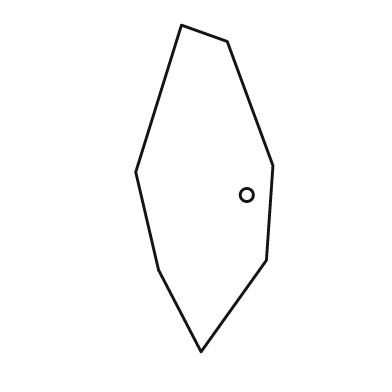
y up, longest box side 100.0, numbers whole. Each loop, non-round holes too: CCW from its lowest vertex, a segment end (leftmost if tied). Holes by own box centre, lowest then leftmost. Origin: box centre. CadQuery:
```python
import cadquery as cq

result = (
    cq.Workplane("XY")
    .moveTo(-1.0, -50.0)
    .lineTo(19.0, -22.0)
    .lineTo(21.0, 7.0)
    .lineTo(7.0, 45.0)
    .lineTo(-7.0, 50.0)
    .lineTo(-21.0, 5.0)
    .lineTo(-14.0, -25.0)
    .close()
    .moveTo(13.0, -2.0)
    .circle(2.0)
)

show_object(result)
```